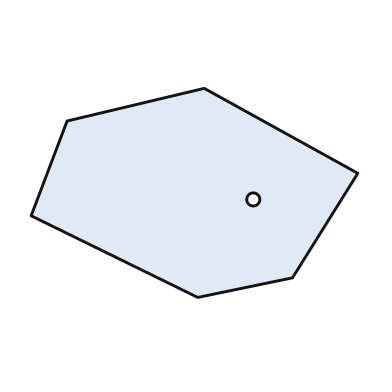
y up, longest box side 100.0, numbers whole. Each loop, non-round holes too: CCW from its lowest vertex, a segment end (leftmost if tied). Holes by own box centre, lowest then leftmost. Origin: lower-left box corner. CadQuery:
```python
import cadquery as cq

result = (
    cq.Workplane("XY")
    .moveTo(51.0, 0.0)
    .lineTo(80.0, 6.0)
    .lineTo(100.0, 38.0)
    .lineTo(53.0, 64.0)
    .lineTo(11.0, 54.0)
    .lineTo(0.0, 25.0)
    .close()
    .moveTo(68.0, 30.0)
    .circle(2.0)
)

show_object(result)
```